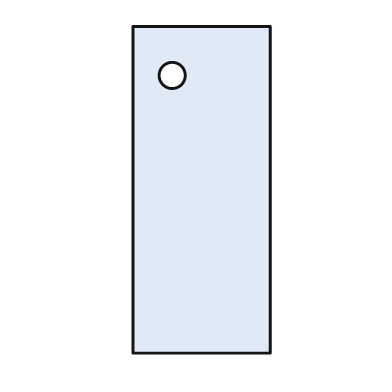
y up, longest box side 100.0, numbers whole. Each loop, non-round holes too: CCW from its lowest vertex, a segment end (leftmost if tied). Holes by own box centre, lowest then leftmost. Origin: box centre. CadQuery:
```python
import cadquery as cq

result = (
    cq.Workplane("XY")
    .moveTo(-21.0, -50.0)
    .lineTo(21.0, -50.0)
    .lineTo(21.0, 50.0)
    .lineTo(-21.0, 50.0)
    .close()
    .moveTo(-9.0, 35.0)
    .circle(4.0)
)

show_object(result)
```